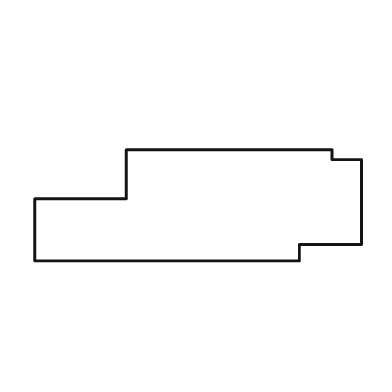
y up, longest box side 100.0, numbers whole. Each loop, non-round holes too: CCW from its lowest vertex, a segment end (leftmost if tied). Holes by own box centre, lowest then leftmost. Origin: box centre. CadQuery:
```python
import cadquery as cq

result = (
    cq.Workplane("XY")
    .moveTo(-50.0, -17.0)
    .lineTo(31.0, -17.0)
    .lineTo(31.0, -12.0)
    .lineTo(50.0, -12.0)
    .lineTo(50.0, 14.0)
    .lineTo(41.0, 14.0)
    .lineTo(41.0, 17.0)
    .lineTo(-22.0, 17.0)
    .lineTo(-22.0, 2.0)
    .lineTo(-50.0, 2.0)
    .close()
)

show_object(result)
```